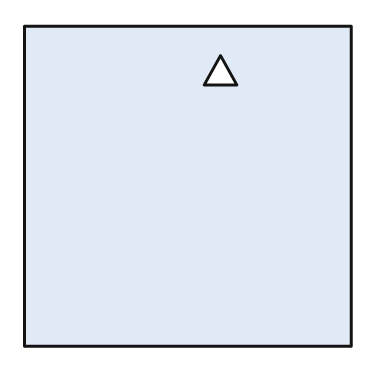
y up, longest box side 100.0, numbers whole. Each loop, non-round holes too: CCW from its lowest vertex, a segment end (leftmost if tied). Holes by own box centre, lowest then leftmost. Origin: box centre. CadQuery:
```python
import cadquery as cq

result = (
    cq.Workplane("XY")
    .moveTo(-50.0, -49.0)
    .lineTo(50.0, -49.0)
    .lineTo(50.0, 49.0)
    .lineTo(-50.0, 49.0)
    .close()
    .moveTo(5.0, 31.0)
    .lineTo(15.0, 31.0)
    .lineTo(10.0, 40.0)
    .close()
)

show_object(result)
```